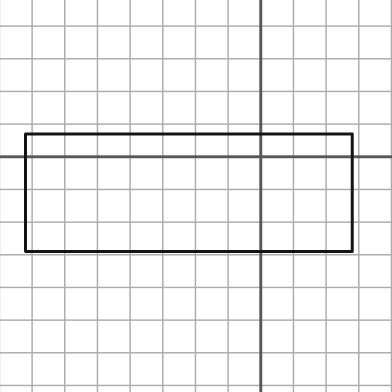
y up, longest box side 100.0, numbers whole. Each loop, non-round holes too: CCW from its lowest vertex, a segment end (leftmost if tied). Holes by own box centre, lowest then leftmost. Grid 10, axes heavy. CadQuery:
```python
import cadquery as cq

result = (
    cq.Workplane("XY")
    .moveTo(-72.0, -29.0)
    .lineTo(28.0, -29.0)
    .lineTo(28.0, 7.0)
    .lineTo(-72.0, 7.0)
    .close()
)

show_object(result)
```